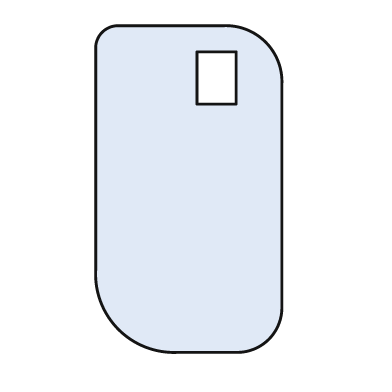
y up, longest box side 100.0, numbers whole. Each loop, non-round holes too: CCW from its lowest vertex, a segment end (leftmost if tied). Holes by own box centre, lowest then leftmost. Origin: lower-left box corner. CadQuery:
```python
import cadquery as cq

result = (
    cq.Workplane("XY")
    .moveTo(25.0, 0.0)
    .lineTo(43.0, 0.0)
    .threePointArc((53.0, 4.0), (57.0, 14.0))
    .lineTo(57.0, 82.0)
    .threePointArc((52.0, 95.0), (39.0, 100.0))
    .lineTo(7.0, 100.0)
    .threePointArc((2.0, 98.0), (0.0, 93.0))
    .lineTo(0.0, 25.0)
    .threePointArc((7.0, 7.0), (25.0, 0.0))
    .close()
    .moveTo(31.0, 76.0)
    .lineTo(43.0, 76.0)
    .lineTo(43.0, 92.0)
    .lineTo(31.0, 92.0)
    .close()
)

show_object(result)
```